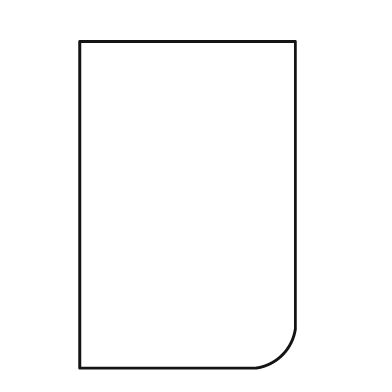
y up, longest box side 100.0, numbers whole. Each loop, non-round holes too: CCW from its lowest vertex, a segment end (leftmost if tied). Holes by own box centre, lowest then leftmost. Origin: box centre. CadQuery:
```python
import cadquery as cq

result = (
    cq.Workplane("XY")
    .moveTo(-33.0, -50.0)
    .lineTo(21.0, -50.0)
    .threePointArc((29.0, -46.0), (33.0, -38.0))
    .lineTo(33.0, 50.0)
    .lineTo(-33.0, 50.0)
    .close()
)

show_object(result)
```